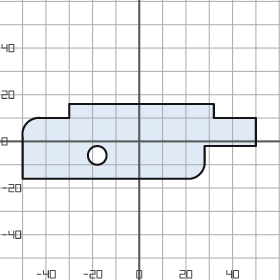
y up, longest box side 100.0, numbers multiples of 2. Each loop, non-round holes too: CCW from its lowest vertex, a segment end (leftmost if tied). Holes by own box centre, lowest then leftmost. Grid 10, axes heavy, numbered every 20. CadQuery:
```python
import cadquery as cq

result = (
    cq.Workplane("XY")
    .moveTo(-50.0, -16.0)
    .lineTo(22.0, -16.0)
    .threePointArc((26.0, -14.0), (28.0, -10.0))
    .lineTo(28.0, -2.0)
    .lineTo(50.0, -2.0)
    .lineTo(50.0, 10.0)
    .lineTo(32.0, 10.0)
    .lineTo(32.0, 16.0)
    .lineTo(-30.0, 16.0)
    .lineTo(-30.0, 10.0)
    .lineTo(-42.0, 10.0)
    .threePointArc((-48.0, 8.0), (-50.0, 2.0))
    .close()
    .moveTo(-18.0, -6.0)
    .circle(4.0)
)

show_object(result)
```